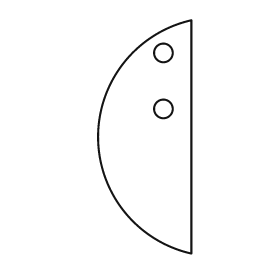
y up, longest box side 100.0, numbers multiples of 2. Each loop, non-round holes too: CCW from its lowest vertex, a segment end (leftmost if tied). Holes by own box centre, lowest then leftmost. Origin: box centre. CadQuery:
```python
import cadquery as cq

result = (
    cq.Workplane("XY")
    .moveTo(20.0, -50.0)
    .lineTo(20.0, 50.0)
    .threePointArc((-20.0, 0.0), (20.0, -50.0))
    .close()
    .moveTo(8.0, 12.0)
    .circle(4.0)
    .moveTo(8.0, 36.0)
    .circle(4.0)
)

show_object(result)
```